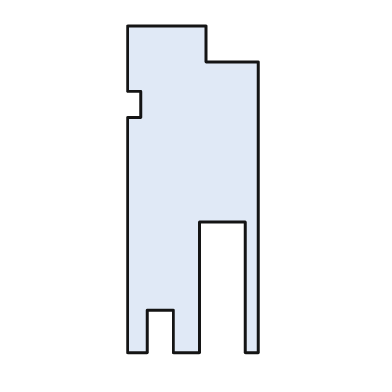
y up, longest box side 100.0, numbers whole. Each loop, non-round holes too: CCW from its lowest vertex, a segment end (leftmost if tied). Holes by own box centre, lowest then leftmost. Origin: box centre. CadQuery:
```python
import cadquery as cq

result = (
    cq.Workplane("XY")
    .moveTo(-20.0, -50.0)
    .lineTo(-14.0, -50.0)
    .lineTo(-14.0, -37.0)
    .lineTo(-6.0, -37.0)
    .lineTo(-6.0, -50.0)
    .lineTo(2.0, -50.0)
    .lineTo(2.0, -10.0)
    .lineTo(16.0, -10.0)
    .lineTo(16.0, -50.0)
    .lineTo(20.0, -50.0)
    .lineTo(20.0, 39.0)
    .lineTo(4.0, 39.0)
    .lineTo(4.0, 50.0)
    .lineTo(-20.0, 50.0)
    .lineTo(-20.0, 30.0)
    .lineTo(-16.0, 30.0)
    .lineTo(-16.0, 22.0)
    .lineTo(-20.0, 22.0)
    .close()
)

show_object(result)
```